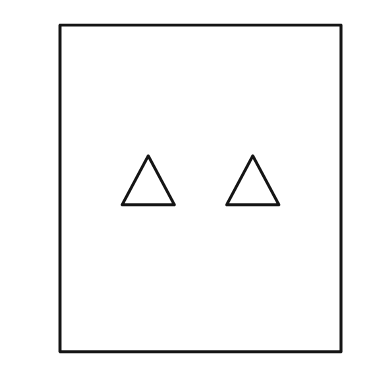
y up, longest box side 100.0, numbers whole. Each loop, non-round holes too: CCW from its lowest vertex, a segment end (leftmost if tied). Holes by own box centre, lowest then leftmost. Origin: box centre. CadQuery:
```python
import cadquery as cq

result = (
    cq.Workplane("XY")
    .moveTo(-43.0, -50.0)
    .lineTo(43.0, -50.0)
    .lineTo(43.0, 50.0)
    .lineTo(-43.0, 50.0)
    .close()
    .moveTo(-24.0, -5.0)
    .lineTo(-8.0, -5.0)
    .lineTo(-16.0, 10.0)
    .close()
    .moveTo(8.0, -5.0)
    .lineTo(24.0, -5.0)
    .lineTo(16.0, 10.0)
    .close()
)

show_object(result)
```